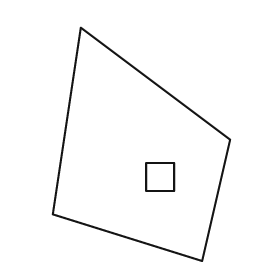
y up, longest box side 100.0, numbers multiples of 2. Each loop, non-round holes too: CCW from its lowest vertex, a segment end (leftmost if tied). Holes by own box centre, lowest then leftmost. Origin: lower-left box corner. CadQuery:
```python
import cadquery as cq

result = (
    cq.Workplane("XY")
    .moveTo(64.0, 0.0)
    .lineTo(76.0, 52.0)
    .lineTo(12.0, 100.0)
    .lineTo(0.0, 20.0)
    .close()
    .moveTo(40.0, 30.0)
    .lineTo(52.0, 30.0)
    .lineTo(52.0, 42.0)
    .lineTo(40.0, 42.0)
    .close()
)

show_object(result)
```